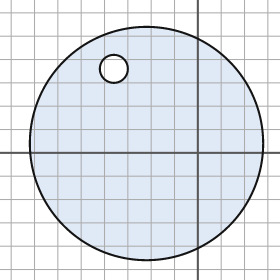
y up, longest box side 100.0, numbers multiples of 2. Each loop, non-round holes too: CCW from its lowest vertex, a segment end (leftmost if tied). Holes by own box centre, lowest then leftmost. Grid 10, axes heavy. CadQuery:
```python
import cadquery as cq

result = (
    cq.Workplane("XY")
    .moveTo(-22.0, 4.0)
    .circle(50.0)
    .moveTo(-36.0, 36.0)
    .circle(6.0)
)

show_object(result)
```